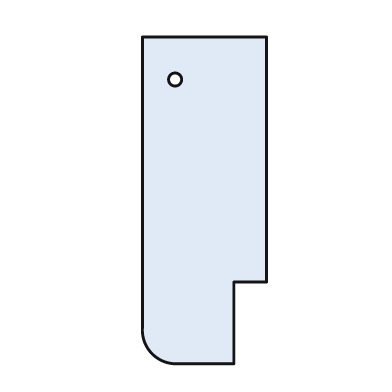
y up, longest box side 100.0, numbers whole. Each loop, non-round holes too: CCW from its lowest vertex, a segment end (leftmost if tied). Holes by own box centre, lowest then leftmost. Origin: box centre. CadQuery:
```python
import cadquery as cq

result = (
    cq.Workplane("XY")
    .moveTo(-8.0, -50.0)
    .lineTo(9.0, -50.0)
    .lineTo(9.0, -25.0)
    .lineTo(19.0, -25.0)
    .lineTo(19.0, 50.0)
    .lineTo(-19.0, 50.0)
    .lineTo(-19.0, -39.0)
    .threePointArc((-16.0, -47.0), (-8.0, -50.0))
    .close()
    .moveTo(-9.0, 37.0)
    .circle(2.0)
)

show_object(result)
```